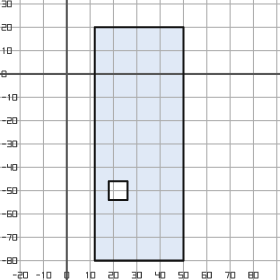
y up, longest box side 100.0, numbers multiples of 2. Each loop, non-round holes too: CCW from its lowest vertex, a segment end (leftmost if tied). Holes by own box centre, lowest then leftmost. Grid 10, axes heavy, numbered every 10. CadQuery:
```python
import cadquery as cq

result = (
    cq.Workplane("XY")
    .moveTo(12.0, -80.0)
    .lineTo(50.0, -80.0)
    .lineTo(50.0, 20.0)
    .lineTo(12.0, 20.0)
    .close()
    .moveTo(18.0, -54.0)
    .lineTo(26.0, -54.0)
    .lineTo(26.0, -46.0)
    .lineTo(18.0, -46.0)
    .close()
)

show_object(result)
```